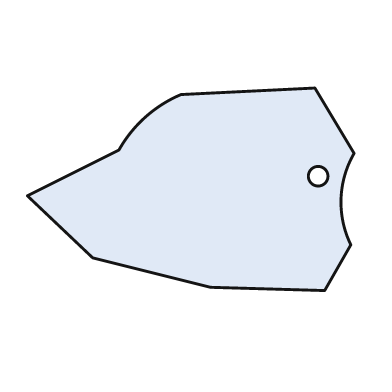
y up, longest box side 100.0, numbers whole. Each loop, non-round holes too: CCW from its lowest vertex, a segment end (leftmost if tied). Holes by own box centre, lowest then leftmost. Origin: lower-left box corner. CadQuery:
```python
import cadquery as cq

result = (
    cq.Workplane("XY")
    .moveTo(91.0, 0.0)
    .lineTo(99.0, 14.0)
    .threePointArc((96.0, 28.0), (100.0, 42.0))
    .lineTo(88.0, 62.0)
    .lineTo(47.0, 60.0)
    .threePointArc((36.0, 53.0), (28.0, 43.0))
    .lineTo(0.0, 29.0)
    .lineTo(20.0, 10.0)
    .lineTo(56.0, 1.0)
    .close()
    .moveTo(89.0, 35.0)
    .circle(3.0)
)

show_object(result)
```